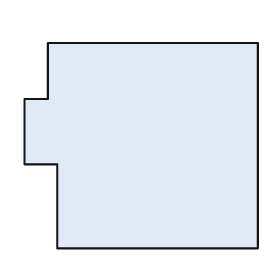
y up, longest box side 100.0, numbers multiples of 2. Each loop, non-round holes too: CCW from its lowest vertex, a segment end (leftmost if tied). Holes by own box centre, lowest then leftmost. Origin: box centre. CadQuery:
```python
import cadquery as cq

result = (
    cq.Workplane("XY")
    .moveTo(-36.0, -44.0)
    .lineTo(50.0, -44.0)
    .lineTo(50.0, 44.0)
    .lineTo(-40.0, 44.0)
    .lineTo(-40.0, 20.0)
    .lineTo(-50.0, 20.0)
    .lineTo(-50.0, -8.0)
    .lineTo(-36.0, -8.0)
    .close()
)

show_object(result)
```